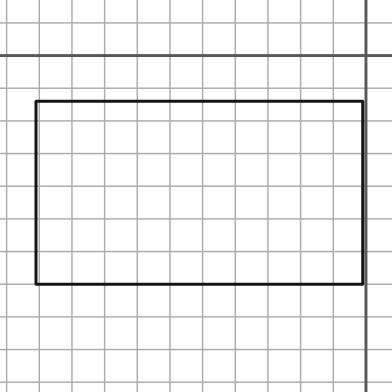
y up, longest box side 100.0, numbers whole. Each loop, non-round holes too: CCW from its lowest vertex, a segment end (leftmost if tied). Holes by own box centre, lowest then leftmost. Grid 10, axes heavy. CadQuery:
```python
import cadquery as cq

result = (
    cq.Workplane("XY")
    .moveTo(-101.0, -70.0)
    .lineTo(-1.0, -70.0)
    .lineTo(-1.0, -14.0)
    .lineTo(-101.0, -14.0)
    .close()
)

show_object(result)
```